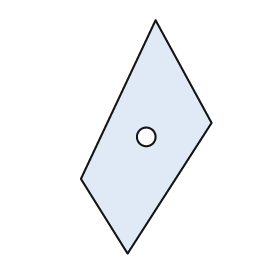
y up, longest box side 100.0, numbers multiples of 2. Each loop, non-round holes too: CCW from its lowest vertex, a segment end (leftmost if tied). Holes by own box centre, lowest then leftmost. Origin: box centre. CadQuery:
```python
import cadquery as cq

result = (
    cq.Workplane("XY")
    .moveTo(-8.0, -50.0)
    .lineTo(28.0, 6.0)
    .lineTo(4.0, 50.0)
    .lineTo(-28.0, -18.0)
    .close()
    .moveTo(0.0, 0.0)
    .circle(4.0)
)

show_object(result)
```